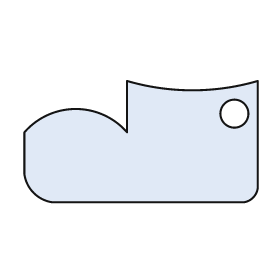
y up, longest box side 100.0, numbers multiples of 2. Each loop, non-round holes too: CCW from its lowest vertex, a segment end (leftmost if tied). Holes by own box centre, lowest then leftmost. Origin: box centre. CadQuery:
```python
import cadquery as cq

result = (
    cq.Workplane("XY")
    .moveTo(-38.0, -26.0)
    .lineTo(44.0, -26.0)
    .threePointArc((48.0, -24.0), (50.0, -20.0))
    .lineTo(50.0, 26.0)
    .threePointArc((22.0, 22.0), (-6.0, 26.0))
    .lineTo(-6.0, 4.0)
    .threePointArc((-28.0, 14.0), (-50.0, 4.0))
    .lineTo(-50.0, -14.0)
    .threePointArc((-46.0, -22.0), (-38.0, -26.0))
    .close()
    .moveTo(40.0, 12.0)
    .circle(6.0)
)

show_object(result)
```